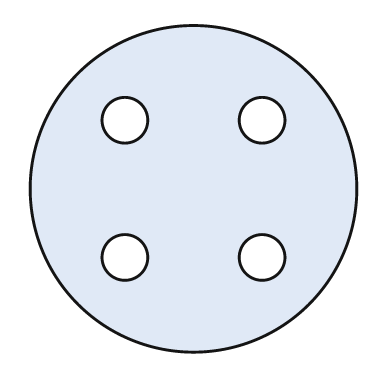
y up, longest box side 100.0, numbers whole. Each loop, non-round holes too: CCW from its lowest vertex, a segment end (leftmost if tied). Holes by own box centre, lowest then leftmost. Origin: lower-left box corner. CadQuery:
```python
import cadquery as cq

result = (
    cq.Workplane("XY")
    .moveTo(50.0, 50.0)
    .circle(50.0)
    .moveTo(29.0, 29.0)
    .circle(7.0)
    .moveTo(71.0, 29.0)
    .circle(7.0)
    .moveTo(29.0, 71.0)
    .circle(7.0)
    .moveTo(71.0, 71.0)
    .circle(7.0)
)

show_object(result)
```